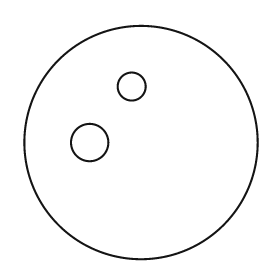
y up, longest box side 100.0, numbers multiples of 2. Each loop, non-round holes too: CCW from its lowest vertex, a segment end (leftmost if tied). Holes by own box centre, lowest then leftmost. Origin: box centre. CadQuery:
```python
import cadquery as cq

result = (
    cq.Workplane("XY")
    .moveTo(0.0, 0.0)
    .circle(50.0)
    .moveTo(-22.0, 0.0)
    .circle(8.0)
    .moveTo(-4.0, 24.0)
    .circle(6.0)
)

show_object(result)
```